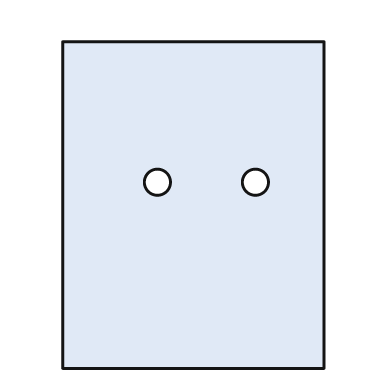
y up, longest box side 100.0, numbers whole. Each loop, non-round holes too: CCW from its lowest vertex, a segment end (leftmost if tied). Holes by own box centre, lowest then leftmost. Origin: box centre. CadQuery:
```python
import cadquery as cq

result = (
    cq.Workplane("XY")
    .moveTo(-40.0, -50.0)
    .lineTo(40.0, -50.0)
    .lineTo(40.0, 50.0)
    .lineTo(-40.0, 50.0)
    .close()
    .moveTo(-11.0, 7.0)
    .circle(4.0)
    .moveTo(19.0, 7.0)
    .circle(4.0)
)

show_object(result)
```